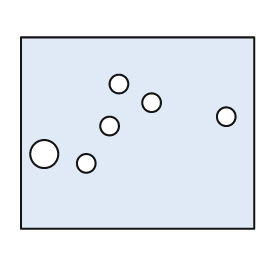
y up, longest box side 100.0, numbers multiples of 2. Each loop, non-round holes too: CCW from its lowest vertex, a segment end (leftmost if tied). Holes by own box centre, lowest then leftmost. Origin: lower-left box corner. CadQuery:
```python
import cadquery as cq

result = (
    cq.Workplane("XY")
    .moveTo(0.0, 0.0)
    .lineTo(100.0, 0.0)
    .lineTo(100.0, 82.0)
    .lineTo(0.0, 82.0)
    .close()
    .moveTo(28.0, 28.0)
    .circle(4.0)
    .moveTo(10.0, 32.0)
    .circle(6.0)
    .moveTo(38.0, 44.0)
    .circle(4.0)
    .moveTo(88.0, 48.0)
    .circle(4.0)
    .moveTo(56.0, 54.0)
    .circle(4.0)
    .moveTo(42.0, 62.0)
    .circle(4.0)
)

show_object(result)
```